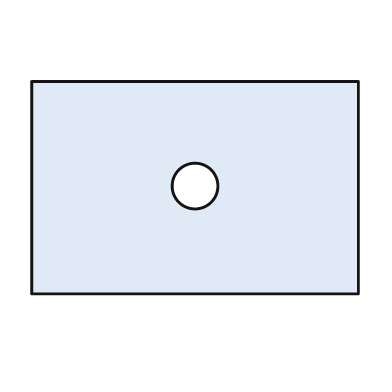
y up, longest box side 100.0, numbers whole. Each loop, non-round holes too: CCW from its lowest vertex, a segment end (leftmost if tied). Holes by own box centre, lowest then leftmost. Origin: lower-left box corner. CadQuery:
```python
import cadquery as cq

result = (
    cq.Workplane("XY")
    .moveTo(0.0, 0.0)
    .lineTo(100.0, 0.0)
    .lineTo(100.0, 65.0)
    .lineTo(0.0, 65.0)
    .close()
    .moveTo(50.0, 33.0)
    .circle(7.0)
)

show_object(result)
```